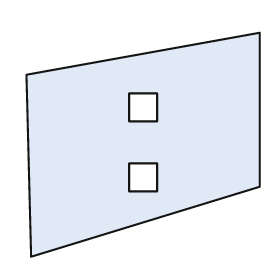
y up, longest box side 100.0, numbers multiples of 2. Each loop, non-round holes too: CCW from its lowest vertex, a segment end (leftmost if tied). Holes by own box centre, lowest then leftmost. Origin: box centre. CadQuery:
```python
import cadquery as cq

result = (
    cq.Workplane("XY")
    .moveTo(-48.0, -48.0)
    .lineTo(50.0, -18.0)
    .lineTo(50.0, 48.0)
    .lineTo(-50.0, 30.0)
    .close()
    .moveTo(-6.0, -20.0)
    .lineTo(6.0, -20.0)
    .lineTo(6.0, -8.0)
    .lineTo(-6.0, -8.0)
    .close()
    .moveTo(-6.0, 10.0)
    .lineTo(6.0, 10.0)
    .lineTo(6.0, 22.0)
    .lineTo(-6.0, 22.0)
    .close()
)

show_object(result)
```